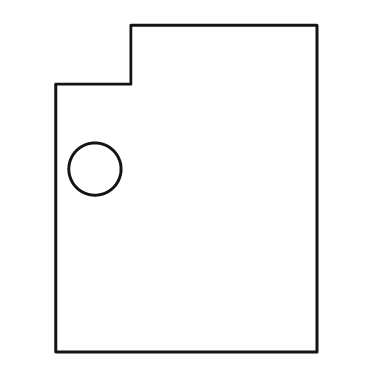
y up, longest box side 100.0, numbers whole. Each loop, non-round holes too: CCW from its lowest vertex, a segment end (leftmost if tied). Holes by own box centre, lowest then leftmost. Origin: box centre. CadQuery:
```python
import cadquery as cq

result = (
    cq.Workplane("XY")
    .moveTo(-40.0, -50.0)
    .lineTo(40.0, -50.0)
    .lineTo(40.0, 50.0)
    .lineTo(-17.0, 50.0)
    .lineTo(-17.0, 32.0)
    .lineTo(-40.0, 32.0)
    .close()
    .moveTo(-28.0, 6.0)
    .circle(8.0)
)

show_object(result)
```